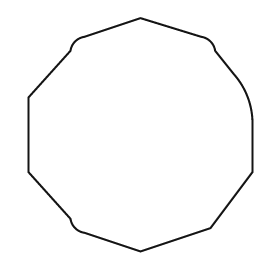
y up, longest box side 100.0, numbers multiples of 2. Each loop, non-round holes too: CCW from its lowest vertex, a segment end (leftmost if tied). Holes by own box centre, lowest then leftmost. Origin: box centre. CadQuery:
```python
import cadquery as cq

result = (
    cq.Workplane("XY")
    .moveTo(0.0, -50.0)
    .lineTo(30.0, -40.0)
    .lineTo(48.0, -16.0)
    .lineTo(48.0, 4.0)
    .threePointArc((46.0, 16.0), (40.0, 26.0))
    .lineTo(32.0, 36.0)
    .threePointArc((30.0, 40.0), (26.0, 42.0))
    .lineTo(0.0, 50.0)
    .lineTo(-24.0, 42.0)
    .threePointArc((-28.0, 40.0), (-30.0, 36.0))
    .lineTo(-48.0, 16.0)
    .lineTo(-48.0, -16.0)
    .lineTo(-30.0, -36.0)
    .threePointArc((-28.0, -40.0), (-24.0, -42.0))
    .close()
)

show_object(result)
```